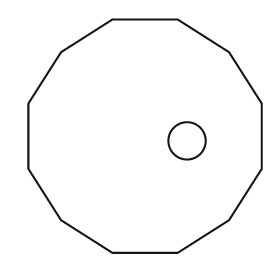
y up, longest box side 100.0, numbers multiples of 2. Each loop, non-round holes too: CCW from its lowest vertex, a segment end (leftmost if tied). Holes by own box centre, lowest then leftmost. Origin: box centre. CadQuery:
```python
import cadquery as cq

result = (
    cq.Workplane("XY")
    .moveTo(-14.0, -50.0)
    .lineTo(14.0, -50.0)
    .lineTo(36.0, -36.0)
    .lineTo(50.0, -14.0)
    .lineTo(50.0, 14.0)
    .lineTo(36.0, 36.0)
    .lineTo(14.0, 50.0)
    .lineTo(-14.0, 50.0)
    .lineTo(-36.0, 36.0)
    .lineTo(-50.0, 14.0)
    .lineTo(-50.0, -14.0)
    .lineTo(-36.0, -36.0)
    .close()
    .moveTo(18.0, -2.0)
    .circle(8.0)
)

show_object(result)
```